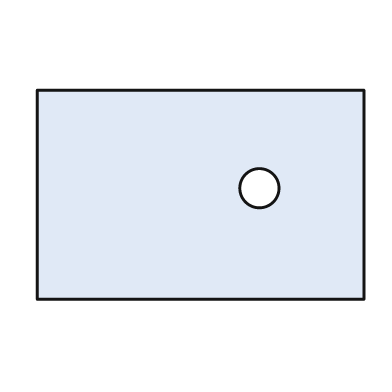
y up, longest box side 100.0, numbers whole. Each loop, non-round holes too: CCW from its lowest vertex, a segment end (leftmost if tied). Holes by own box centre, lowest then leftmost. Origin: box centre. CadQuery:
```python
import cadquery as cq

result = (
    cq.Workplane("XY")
    .moveTo(-50.0, -32.0)
    .lineTo(50.0, -32.0)
    .lineTo(50.0, 32.0)
    .lineTo(-50.0, 32.0)
    .close()
    .moveTo(18.0, 2.0)
    .circle(6.0)
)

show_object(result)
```